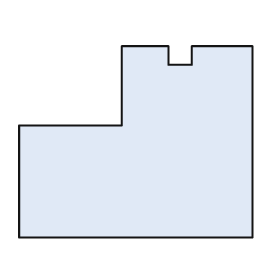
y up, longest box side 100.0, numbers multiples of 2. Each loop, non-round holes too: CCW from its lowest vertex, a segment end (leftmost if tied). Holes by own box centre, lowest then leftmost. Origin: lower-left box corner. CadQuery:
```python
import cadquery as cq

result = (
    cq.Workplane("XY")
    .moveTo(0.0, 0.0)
    .lineTo(100.0, 0.0)
    .lineTo(100.0, 82.0)
    .lineTo(74.0, 82.0)
    .lineTo(74.0, 74.0)
    .lineTo(64.0, 74.0)
    .lineTo(64.0, 82.0)
    .lineTo(44.0, 82.0)
    .lineTo(44.0, 48.0)
    .lineTo(0.0, 48.0)
    .close()
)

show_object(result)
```